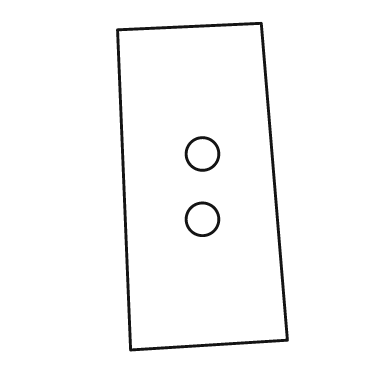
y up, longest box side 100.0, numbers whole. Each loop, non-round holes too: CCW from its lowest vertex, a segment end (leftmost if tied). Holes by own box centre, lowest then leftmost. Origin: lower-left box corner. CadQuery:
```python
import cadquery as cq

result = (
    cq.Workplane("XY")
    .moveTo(4.0, 0.0)
    .lineTo(52.0, 3.0)
    .lineTo(44.0, 100.0)
    .lineTo(0.0, 98.0)
    .close()
    .moveTo(26.0, 40.0)
    .circle(5.0)
    .moveTo(26.0, 60.0)
    .circle(5.0)
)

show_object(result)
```